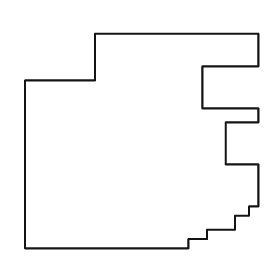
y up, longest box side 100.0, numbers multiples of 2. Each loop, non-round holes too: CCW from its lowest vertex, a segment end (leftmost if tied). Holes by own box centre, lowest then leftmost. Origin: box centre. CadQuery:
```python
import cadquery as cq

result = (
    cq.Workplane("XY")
    .moveTo(-50.0, -46.0)
    .lineTo(20.0, -46.0)
    .lineTo(20.0, -42.0)
    .lineTo(28.0, -42.0)
    .lineTo(28.0, -38.0)
    .lineTo(40.0, -38.0)
    .lineTo(40.0, -32.0)
    .lineTo(46.0, -32.0)
    .lineTo(46.0, -28.0)
    .lineTo(50.0, -28.0)
    .lineTo(50.0, -10.0)
    .lineTo(36.0, -10.0)
    .lineTo(36.0, 8.0)
    .lineTo(50.0, 8.0)
    .lineTo(50.0, 14.0)
    .lineTo(26.0, 14.0)
    .lineTo(26.0, 32.0)
    .lineTo(50.0, 32.0)
    .lineTo(50.0, 46.0)
    .lineTo(-20.0, 46.0)
    .lineTo(-20.0, 26.0)
    .lineTo(-50.0, 26.0)
    .close()
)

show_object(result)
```